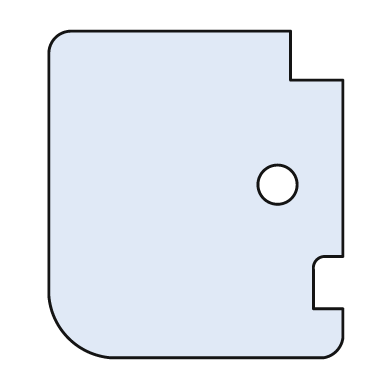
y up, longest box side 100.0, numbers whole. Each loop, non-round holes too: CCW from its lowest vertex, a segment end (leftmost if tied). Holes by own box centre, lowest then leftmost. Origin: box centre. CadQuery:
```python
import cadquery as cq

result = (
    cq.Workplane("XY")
    .moveTo(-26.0, -50.0)
    .lineTo(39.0, -50.0)
    .threePointArc((43.0, -48.0), (45.0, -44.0))
    .lineTo(45.0, -35.0)
    .lineTo(36.0, -35.0)
    .lineTo(36.0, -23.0)
    .threePointArc((37.0, -20.0), (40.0, -19.0))
    .lineTo(45.0, -19.0)
    .lineTo(45.0, 35.0)
    .lineTo(29.0, 35.0)
    .lineTo(29.0, 50.0)
    .lineTo(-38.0, 50.0)
    .threePointArc((-43.0, 48.0), (-45.0, 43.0))
    .lineTo(-45.0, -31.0)
    .threePointArc((-39.0, -44.0), (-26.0, -50.0))
    .close()
    .moveTo(25.0, 3.0)
    .circle(6.0)
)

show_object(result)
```